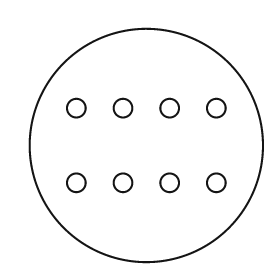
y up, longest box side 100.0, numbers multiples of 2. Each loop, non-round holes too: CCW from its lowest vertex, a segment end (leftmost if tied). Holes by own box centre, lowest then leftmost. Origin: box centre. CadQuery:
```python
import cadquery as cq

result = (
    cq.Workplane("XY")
    .moveTo(0.0, 0.0)
    .circle(50.0)
    .moveTo(-30.0, -16.0)
    .circle(4.0)
    .moveTo(-10.0, -16.0)
    .circle(4.0)
    .moveTo(10.0, -16.0)
    .circle(4.0)
    .moveTo(30.0, -16.0)
    .circle(4.0)
    .moveTo(-30.0, 16.0)
    .circle(4.0)
    .moveTo(-10.0, 16.0)
    .circle(4.0)
    .moveTo(10.0, 16.0)
    .circle(4.0)
    .moveTo(30.0, 16.0)
    .circle(4.0)
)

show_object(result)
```